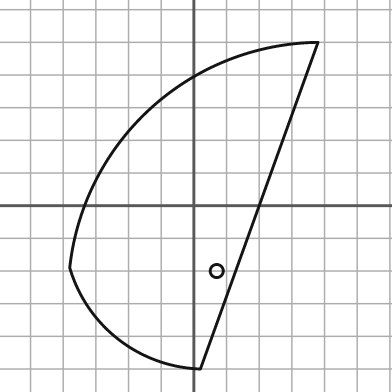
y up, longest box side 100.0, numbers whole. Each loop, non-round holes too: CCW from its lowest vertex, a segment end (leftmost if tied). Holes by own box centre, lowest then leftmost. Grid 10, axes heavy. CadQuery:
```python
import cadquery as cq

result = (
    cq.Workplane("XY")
    .moveTo(2.0, -50.0)
    .lineTo(38.0, 50.0)
    .threePointArc((-13.0, 30.0), (-38.0, -19.0))
    .threePointArc((-23.0, -41.0), (2.0, -50.0))
    .close()
    .moveTo(7.0, -20.0)
    .circle(2.0)
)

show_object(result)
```